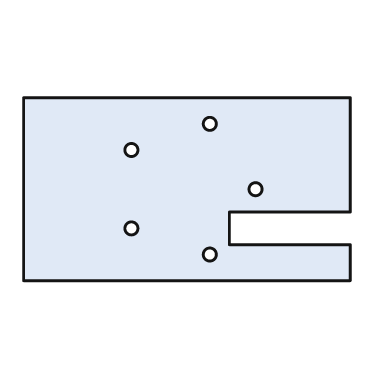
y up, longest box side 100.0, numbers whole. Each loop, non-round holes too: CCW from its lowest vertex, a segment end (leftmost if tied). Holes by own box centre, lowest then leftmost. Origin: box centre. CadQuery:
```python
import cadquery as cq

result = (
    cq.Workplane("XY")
    .moveTo(-50.0, -28.0)
    .lineTo(50.0, -28.0)
    .lineTo(50.0, -17.0)
    .lineTo(13.0, -17.0)
    .lineTo(13.0, -7.0)
    .lineTo(50.0, -7.0)
    .lineTo(50.0, 28.0)
    .lineTo(-50.0, 28.0)
    .close()
    .moveTo(7.0, -20.0)
    .circle(2.0)
    .moveTo(-17.0, -12.0)
    .circle(2.0)
    .moveTo(21.0, 0.0)
    .circle(2.0)
    .moveTo(-17.0, 12.0)
    .circle(2.0)
    .moveTo(7.0, 20.0)
    .circle(2.0)
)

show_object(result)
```